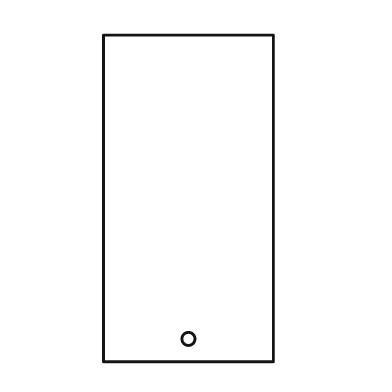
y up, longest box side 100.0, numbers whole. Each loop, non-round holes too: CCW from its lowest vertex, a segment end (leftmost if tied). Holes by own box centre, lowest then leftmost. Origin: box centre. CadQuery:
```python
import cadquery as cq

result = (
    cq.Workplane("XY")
    .moveTo(-26.0, -50.0)
    .lineTo(26.0, -50.0)
    .lineTo(26.0, 50.0)
    .lineTo(-26.0, 50.0)
    .close()
    .moveTo(0.0, -43.0)
    .circle(2.0)
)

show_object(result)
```